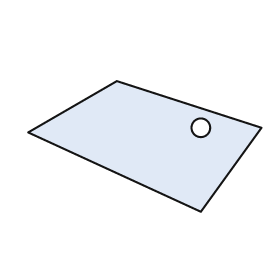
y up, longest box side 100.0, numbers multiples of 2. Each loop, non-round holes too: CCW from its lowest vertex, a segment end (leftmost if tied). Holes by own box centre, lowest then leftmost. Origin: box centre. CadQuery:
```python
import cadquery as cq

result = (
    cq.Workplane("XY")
    .moveTo(24.0, -28.0)
    .lineTo(50.0, 8.0)
    .lineTo(-12.0, 28.0)
    .lineTo(-50.0, 6.0)
    .close()
    .moveTo(24.0, 8.0)
    .circle(4.0)
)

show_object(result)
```